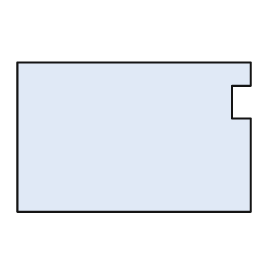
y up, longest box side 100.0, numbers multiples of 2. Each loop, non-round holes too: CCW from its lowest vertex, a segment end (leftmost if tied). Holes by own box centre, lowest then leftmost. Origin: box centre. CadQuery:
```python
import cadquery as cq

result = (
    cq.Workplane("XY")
    .moveTo(-50.0, -32.0)
    .lineTo(50.0, -32.0)
    .lineTo(50.0, 8.0)
    .lineTo(42.0, 8.0)
    .lineTo(42.0, 22.0)
    .lineTo(50.0, 22.0)
    .lineTo(50.0, 32.0)
    .lineTo(-50.0, 32.0)
    .close()
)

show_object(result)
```